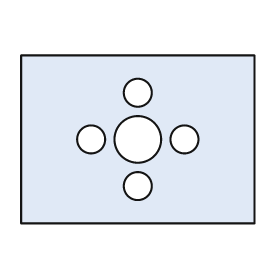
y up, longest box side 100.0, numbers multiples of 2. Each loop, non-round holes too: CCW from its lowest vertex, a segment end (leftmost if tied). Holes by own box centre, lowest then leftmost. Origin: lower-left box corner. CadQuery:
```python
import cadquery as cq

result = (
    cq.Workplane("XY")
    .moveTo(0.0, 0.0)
    .lineTo(100.0, 0.0)
    .lineTo(100.0, 72.0)
    .lineTo(0.0, 72.0)
    .close()
    .moveTo(50.0, 16.0)
    .circle(6.0)
    .moveTo(30.0, 36.0)
    .circle(6.0)
    .moveTo(50.0, 36.0)
    .circle(10.0)
    .moveTo(70.0, 36.0)
    .circle(6.0)
    .moveTo(50.0, 56.0)
    .circle(6.0)
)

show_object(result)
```